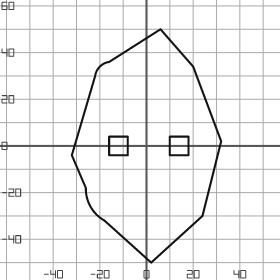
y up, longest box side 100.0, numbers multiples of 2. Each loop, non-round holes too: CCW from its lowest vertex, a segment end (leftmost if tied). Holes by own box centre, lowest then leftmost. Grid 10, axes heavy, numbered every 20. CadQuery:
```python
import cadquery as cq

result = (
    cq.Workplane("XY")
    .moveTo(2.0, -50.0)
    .lineTo(24.0, -30.0)
    .lineTo(32.0, 2.0)
    .lineTo(20.0, 34.0)
    .lineTo(6.0, 50.0)
    .lineTo(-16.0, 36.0)
    .threePointArc((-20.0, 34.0), (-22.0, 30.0))
    .lineTo(-32.0, -4.0)
    .lineTo(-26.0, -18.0)
    .threePointArc((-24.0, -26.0), (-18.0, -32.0))
    .close()
    .moveTo(-16.0, -4.0)
    .lineTo(-8.0, -4.0)
    .lineTo(-8.0, 4.0)
    .lineTo(-16.0, 4.0)
    .close()
    .moveTo(10.0, -4.0)
    .lineTo(18.0, -4.0)
    .lineTo(18.0, 4.0)
    .lineTo(10.0, 4.0)
    .close()
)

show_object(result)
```